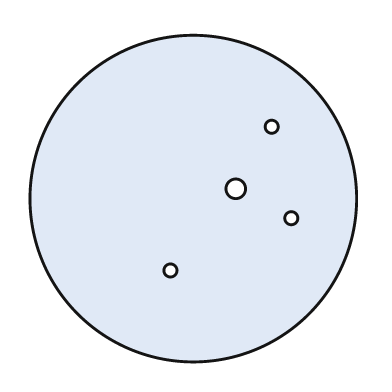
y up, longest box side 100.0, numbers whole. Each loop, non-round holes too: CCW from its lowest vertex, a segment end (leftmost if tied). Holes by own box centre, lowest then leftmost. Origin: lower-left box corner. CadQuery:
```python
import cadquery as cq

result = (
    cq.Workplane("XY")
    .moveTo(50.0, 50.0)
    .circle(50.0)
    .moveTo(43.0, 28.0)
    .circle(2.0)
    .moveTo(80.0, 44.0)
    .circle(2.0)
    .moveTo(63.0, 53.0)
    .circle(3.0)
    .moveTo(74.0, 72.0)
    .circle(2.0)
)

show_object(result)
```